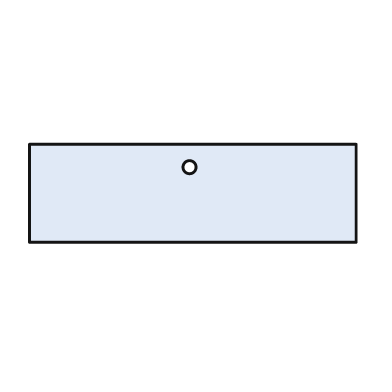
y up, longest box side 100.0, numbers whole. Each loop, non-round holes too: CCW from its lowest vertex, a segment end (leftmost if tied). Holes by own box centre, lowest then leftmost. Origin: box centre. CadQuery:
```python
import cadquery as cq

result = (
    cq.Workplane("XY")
    .moveTo(-50.0, -15.0)
    .lineTo(50.0, -15.0)
    .lineTo(50.0, 15.0)
    .lineTo(-50.0, 15.0)
    .close()
    .moveTo(-1.0, 8.0)
    .circle(2.0)
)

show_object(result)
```